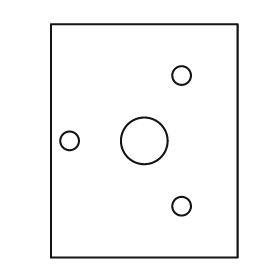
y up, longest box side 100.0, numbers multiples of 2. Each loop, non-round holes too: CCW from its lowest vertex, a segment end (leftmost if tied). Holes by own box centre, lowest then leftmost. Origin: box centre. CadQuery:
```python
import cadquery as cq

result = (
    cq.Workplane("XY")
    .moveTo(-40.0, -50.0)
    .lineTo(40.0, -50.0)
    .lineTo(40.0, 50.0)
    .lineTo(-40.0, 50.0)
    .close()
    .moveTo(16.0, -28.0)
    .circle(4.0)
    .moveTo(-32.0, 0.0)
    .circle(4.0)
    .moveTo(0.0, 0.0)
    .circle(10.0)
    .moveTo(16.0, 28.0)
    .circle(4.0)
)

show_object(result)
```